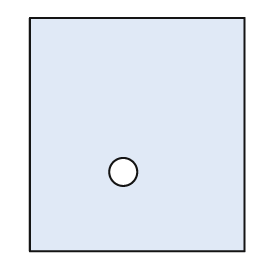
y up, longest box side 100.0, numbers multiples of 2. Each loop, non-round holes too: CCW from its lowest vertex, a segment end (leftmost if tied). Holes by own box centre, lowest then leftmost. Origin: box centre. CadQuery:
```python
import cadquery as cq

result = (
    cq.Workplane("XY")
    .moveTo(-46.0, -50.0)
    .lineTo(46.0, -50.0)
    .lineTo(46.0, 50.0)
    .lineTo(-46.0, 50.0)
    .close()
    .moveTo(-6.0, -16.0)
    .circle(6.0)
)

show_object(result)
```